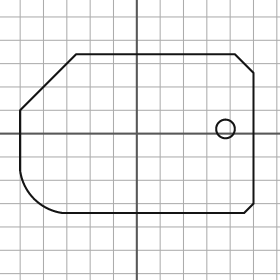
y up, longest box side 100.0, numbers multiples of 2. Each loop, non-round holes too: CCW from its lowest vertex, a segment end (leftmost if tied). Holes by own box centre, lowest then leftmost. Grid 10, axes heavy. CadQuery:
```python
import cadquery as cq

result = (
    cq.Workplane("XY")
    .moveTo(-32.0, -34.0)
    .lineTo(46.0, -34.0)
    .lineTo(50.0, -30.0)
    .lineTo(50.0, 26.0)
    .lineTo(42.0, 34.0)
    .lineTo(-26.0, 34.0)
    .lineTo(-50.0, 10.0)
    .lineTo(-50.0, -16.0)
    .threePointArc((-44.0, -28.0), (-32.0, -34.0))
    .close()
    .moveTo(38.0, 2.0)
    .circle(4.0)
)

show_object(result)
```